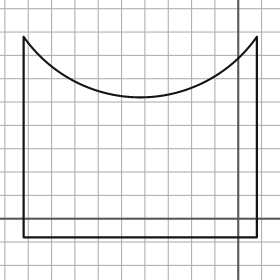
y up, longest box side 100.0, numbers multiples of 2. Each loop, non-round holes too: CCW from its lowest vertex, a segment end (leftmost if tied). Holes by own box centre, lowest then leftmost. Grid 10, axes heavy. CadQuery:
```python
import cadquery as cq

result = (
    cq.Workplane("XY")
    .moveTo(-92.0, -8.0)
    .lineTo(8.0, -8.0)
    .lineTo(8.0, 78.0)
    .threePointArc((-42.0, 52.0), (-92.0, 78.0))
    .close()
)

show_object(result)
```